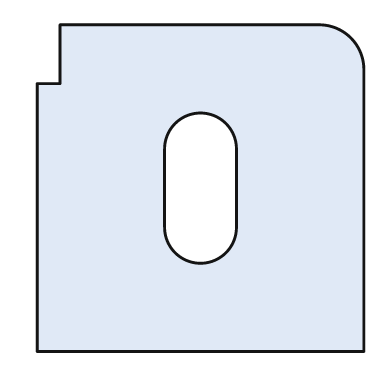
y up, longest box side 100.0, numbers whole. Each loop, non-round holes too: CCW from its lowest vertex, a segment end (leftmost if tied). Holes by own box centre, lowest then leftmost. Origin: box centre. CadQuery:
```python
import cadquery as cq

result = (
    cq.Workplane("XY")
    .moveTo(-50.0, -50.0)
    .lineTo(50.0, -50.0)
    .lineTo(50.0, 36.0)
    .threePointArc((46.0, 46.0), (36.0, 50.0))
    .lineTo(-43.0, 50.0)
    .lineTo(-43.0, 32.0)
    .lineTo(-50.0, 32.0)
    .close()
    .moveTo(-11.0, -12.0)
    .threePointArc((0.0, -23.0), (11.0, -12.0))
    .lineTo(11.0, 12.0)
    .threePointArc((0.0, 23.0), (-11.0, 12.0))
    .close()
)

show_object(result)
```